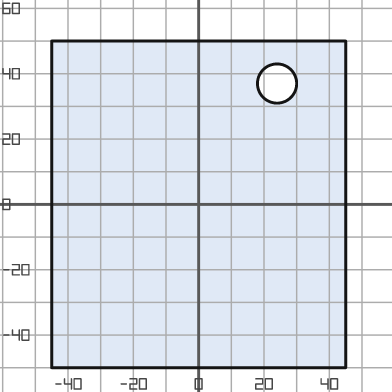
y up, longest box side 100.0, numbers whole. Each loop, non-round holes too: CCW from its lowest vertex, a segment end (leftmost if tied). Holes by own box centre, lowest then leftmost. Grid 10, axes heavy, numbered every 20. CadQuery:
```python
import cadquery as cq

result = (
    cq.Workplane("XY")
    .moveTo(-45.0, -50.0)
    .lineTo(45.0, -50.0)
    .lineTo(45.0, 50.0)
    .lineTo(-45.0, 50.0)
    .close()
    .moveTo(24.0, 37.0)
    .circle(6.0)
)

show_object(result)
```